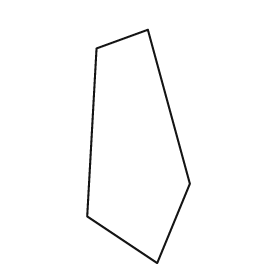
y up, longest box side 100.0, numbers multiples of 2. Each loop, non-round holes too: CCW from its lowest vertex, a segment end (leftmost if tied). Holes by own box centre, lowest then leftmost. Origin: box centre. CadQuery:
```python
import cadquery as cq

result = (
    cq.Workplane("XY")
    .moveTo(8.0, -50.0)
    .lineTo(22.0, -16.0)
    .lineTo(4.0, 50.0)
    .lineTo(-18.0, 42.0)
    .lineTo(-22.0, -30.0)
    .close()
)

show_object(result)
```